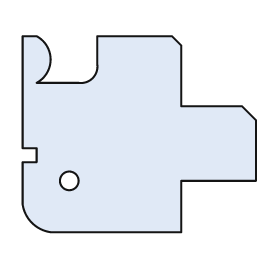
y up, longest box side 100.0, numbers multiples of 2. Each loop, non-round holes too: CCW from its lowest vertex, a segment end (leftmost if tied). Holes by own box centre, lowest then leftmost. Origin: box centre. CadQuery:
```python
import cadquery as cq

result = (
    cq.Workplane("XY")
    .moveTo(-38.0, -42.0)
    .lineTo(18.0, -42.0)
    .lineTo(18.0, -20.0)
    .lineTo(50.0, -20.0)
    .lineTo(50.0, 6.0)
    .lineTo(44.0, 12.0)
    .lineTo(18.0, 12.0)
    .lineTo(18.0, 38.0)
    .lineTo(14.0, 42.0)
    .lineTo(-18.0, 42.0)
    .lineTo(-18.0, 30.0)
    .threePointArc((-20.0, 24.0), (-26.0, 22.0))
    .lineTo(-44.0, 22.0)
    .threePointArc((-38.0, 32.0), (-44.0, 42.0))
    .lineTo(-50.0, 42.0)
    .lineTo(-50.0, -6.0)
    .lineTo(-44.0, -6.0)
    .lineTo(-44.0, -12.0)
    .lineTo(-50.0, -12.0)
    .lineTo(-50.0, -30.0)
    .threePointArc((-46.0, -38.0), (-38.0, -42.0))
    .close()
    .moveTo(-30.0, -20.0)
    .circle(4.0)
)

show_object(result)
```